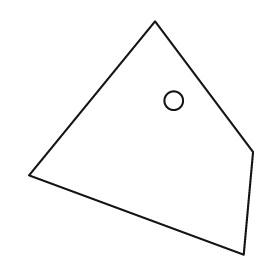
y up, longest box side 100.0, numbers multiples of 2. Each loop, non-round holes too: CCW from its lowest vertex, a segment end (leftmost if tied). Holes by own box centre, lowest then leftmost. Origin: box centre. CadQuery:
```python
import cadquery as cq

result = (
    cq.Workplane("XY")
    .moveTo(44.0, -50.0)
    .lineTo(48.0, -6.0)
    .lineTo(6.0, 50.0)
    .lineTo(-48.0, -16.0)
    .close()
    .moveTo(14.0, 16.0)
    .circle(4.0)
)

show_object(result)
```